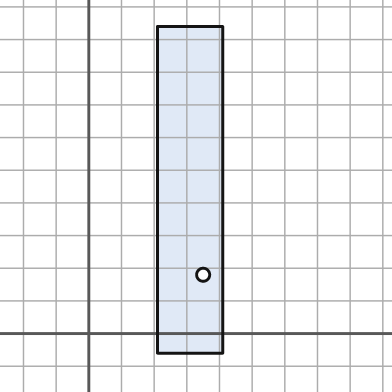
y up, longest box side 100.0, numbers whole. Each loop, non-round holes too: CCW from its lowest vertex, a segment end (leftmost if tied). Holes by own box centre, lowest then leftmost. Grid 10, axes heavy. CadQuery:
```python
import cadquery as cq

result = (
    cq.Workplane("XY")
    .moveTo(21.0, -6.0)
    .lineTo(41.0, -6.0)
    .lineTo(41.0, 94.0)
    .lineTo(21.0, 94.0)
    .close()
    .moveTo(35.0, 18.0)
    .circle(2.0)
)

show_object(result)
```